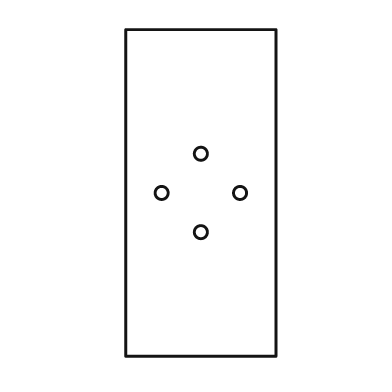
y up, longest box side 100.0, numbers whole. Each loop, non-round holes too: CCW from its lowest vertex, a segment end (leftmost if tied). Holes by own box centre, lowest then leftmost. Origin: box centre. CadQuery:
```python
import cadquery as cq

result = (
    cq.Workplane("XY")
    .moveTo(-23.0, -50.0)
    .lineTo(23.0, -50.0)
    .lineTo(23.0, 50.0)
    .lineTo(-23.0, 50.0)
    .close()
    .moveTo(0.0, -12.0)
    .circle(2.0)
    .moveTo(-12.0, 0.0)
    .circle(2.0)
    .moveTo(12.0, 0.0)
    .circle(2.0)
    .moveTo(0.0, 12.0)
    .circle(2.0)
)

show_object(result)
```